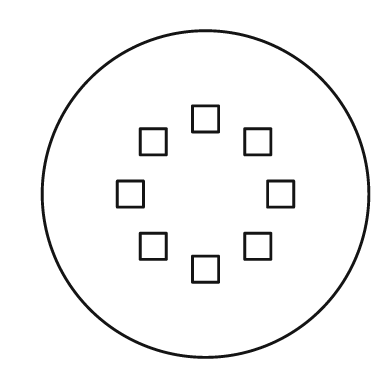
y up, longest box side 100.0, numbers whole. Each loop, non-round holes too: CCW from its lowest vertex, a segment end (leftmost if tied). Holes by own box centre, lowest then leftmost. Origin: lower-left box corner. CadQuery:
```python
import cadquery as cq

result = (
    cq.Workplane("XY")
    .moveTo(50.0, 50.0)
    .circle(50.0)
    .moveTo(46.0, 23.0)
    .lineTo(54.0, 23.0)
    .lineTo(54.0, 31.0)
    .lineTo(46.0, 31.0)
    .close()
    .moveTo(30.0, 30.0)
    .lineTo(38.0, 30.0)
    .lineTo(38.0, 38.0)
    .lineTo(30.0, 38.0)
    .close()
    .moveTo(62.0, 30.0)
    .lineTo(70.0, 30.0)
    .lineTo(70.0, 38.0)
    .lineTo(62.0, 38.0)
    .close()
    .moveTo(23.0, 46.0)
    .lineTo(31.0, 46.0)
    .lineTo(31.0, 54.0)
    .lineTo(23.0, 54.0)
    .close()
    .moveTo(69.0, 46.0)
    .lineTo(77.0, 46.0)
    .lineTo(77.0, 54.0)
    .lineTo(69.0, 54.0)
    .close()
    .moveTo(30.0, 62.0)
    .lineTo(38.0, 62.0)
    .lineTo(38.0, 70.0)
    .lineTo(30.0, 70.0)
    .close()
    .moveTo(62.0, 62.0)
    .lineTo(70.0, 62.0)
    .lineTo(70.0, 70.0)
    .lineTo(62.0, 70.0)
    .close()
    .moveTo(46.0, 69.0)
    .lineTo(54.0, 69.0)
    .lineTo(54.0, 77.0)
    .lineTo(46.0, 77.0)
    .close()
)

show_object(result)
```